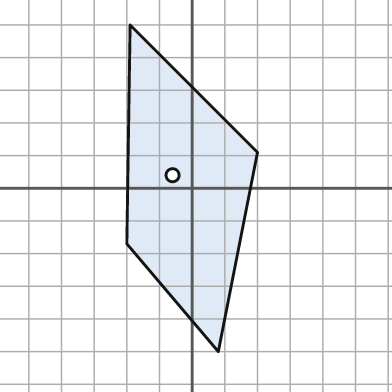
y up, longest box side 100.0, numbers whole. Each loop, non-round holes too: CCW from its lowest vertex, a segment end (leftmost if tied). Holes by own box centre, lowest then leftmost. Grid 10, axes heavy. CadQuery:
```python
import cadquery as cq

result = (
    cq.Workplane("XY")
    .moveTo(8.0, -50.0)
    .lineTo(20.0, 11.0)
    .lineTo(-19.0, 50.0)
    .lineTo(-20.0, -17.0)
    .close()
    .moveTo(-6.0, 4.0)
    .circle(2.0)
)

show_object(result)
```